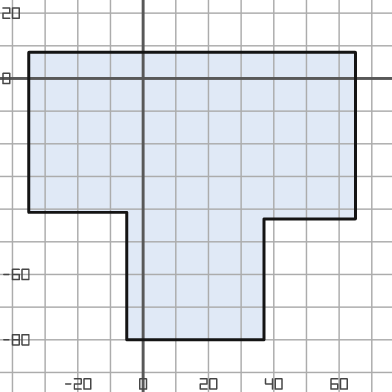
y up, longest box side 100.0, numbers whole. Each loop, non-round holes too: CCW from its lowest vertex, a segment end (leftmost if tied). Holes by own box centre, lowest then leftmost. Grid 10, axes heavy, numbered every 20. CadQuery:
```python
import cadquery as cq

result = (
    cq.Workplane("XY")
    .moveTo(-5.0, -80.0)
    .lineTo(37.0, -80.0)
    .lineTo(37.0, -43.0)
    .lineTo(65.0, -43.0)
    .lineTo(65.0, 8.0)
    .lineTo(-35.0, 8.0)
    .lineTo(-35.0, -41.0)
    .lineTo(-5.0, -41.0)
    .close()
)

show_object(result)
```